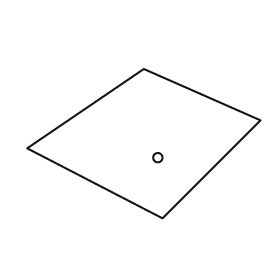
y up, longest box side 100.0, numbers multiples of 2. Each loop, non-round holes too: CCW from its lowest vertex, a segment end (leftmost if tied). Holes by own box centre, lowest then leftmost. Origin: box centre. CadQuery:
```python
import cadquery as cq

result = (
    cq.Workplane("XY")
    .moveTo(8.0, -32.0)
    .lineTo(50.0, 10.0)
    .lineTo(0.0, 32.0)
    .lineTo(-50.0, -2.0)
    .close()
    .moveTo(6.0, -6.0)
    .circle(2.0)
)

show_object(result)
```